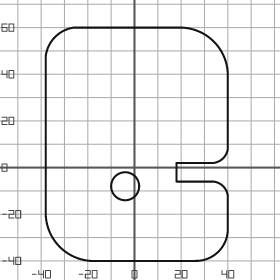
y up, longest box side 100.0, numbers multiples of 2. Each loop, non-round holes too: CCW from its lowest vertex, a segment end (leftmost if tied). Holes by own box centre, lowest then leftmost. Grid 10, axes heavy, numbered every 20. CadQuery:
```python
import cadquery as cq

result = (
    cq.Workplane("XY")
    .moveTo(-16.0, -40.0)
    .lineTo(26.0, -40.0)
    .threePointArc((36.0, -36.0), (40.0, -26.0))
    .lineTo(40.0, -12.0)
    .threePointArc((38.0, -8.0), (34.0, -6.0))
    .lineTo(18.0, -6.0)
    .lineTo(18.0, 2.0)
    .lineTo(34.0, 2.0)
    .threePointArc((38.0, 4.0), (40.0, 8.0))
    .lineTo(40.0, 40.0)
    .threePointArc((34.0, 54.0), (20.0, 60.0))
    .lineTo(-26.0, 60.0)
    .threePointArc((-34.0, 56.0), (-38.0, 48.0))
    .lineTo(-38.0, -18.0)
    .threePointArc((-32.0, -34.0), (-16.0, -40.0))
    .close()
    .moveTo(-4.0, -8.0)
    .circle(6.0)
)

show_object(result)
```